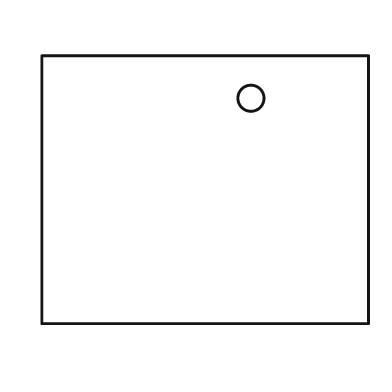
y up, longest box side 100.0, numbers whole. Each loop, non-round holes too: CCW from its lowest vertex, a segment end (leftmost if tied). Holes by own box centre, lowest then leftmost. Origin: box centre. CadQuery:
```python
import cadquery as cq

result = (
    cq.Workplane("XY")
    .moveTo(-50.0, -41.0)
    .lineTo(50.0, -41.0)
    .lineTo(50.0, 41.0)
    .lineTo(-50.0, 41.0)
    .close()
    .moveTo(14.0, 28.0)
    .circle(4.0)
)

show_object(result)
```